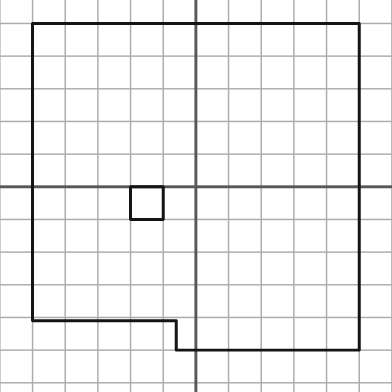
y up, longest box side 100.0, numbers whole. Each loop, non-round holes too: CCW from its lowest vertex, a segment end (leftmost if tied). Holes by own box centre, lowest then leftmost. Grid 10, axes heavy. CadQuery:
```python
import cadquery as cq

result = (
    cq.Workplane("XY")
    .moveTo(-6.0, -50.0)
    .lineTo(50.0, -50.0)
    .lineTo(50.0, 50.0)
    .lineTo(-50.0, 50.0)
    .lineTo(-50.0, -41.0)
    .lineTo(-6.0, -41.0)
    .close()
    .moveTo(-20.0, -10.0)
    .lineTo(-10.0, -10.0)
    .lineTo(-10.0, 0.0)
    .lineTo(-20.0, 0.0)
    .close()
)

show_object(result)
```